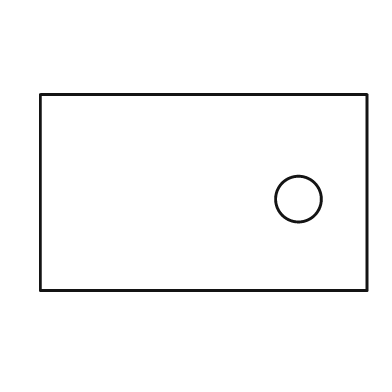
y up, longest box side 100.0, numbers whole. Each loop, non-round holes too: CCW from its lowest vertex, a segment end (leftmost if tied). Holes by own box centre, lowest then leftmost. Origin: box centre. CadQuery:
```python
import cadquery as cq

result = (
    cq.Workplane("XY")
    .moveTo(-50.0, -30.0)
    .lineTo(50.0, -30.0)
    .lineTo(50.0, 30.0)
    .lineTo(-50.0, 30.0)
    .close()
    .moveTo(29.0, -2.0)
    .circle(7.0)
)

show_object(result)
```